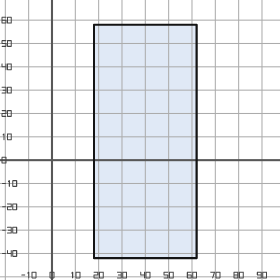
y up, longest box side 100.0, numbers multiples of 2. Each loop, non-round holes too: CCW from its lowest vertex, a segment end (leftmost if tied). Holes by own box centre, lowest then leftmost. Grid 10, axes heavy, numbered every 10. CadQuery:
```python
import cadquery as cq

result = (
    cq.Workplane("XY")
    .moveTo(18.0, -42.0)
    .lineTo(62.0, -42.0)
    .lineTo(62.0, 58.0)
    .lineTo(18.0, 58.0)
    .close()
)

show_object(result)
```